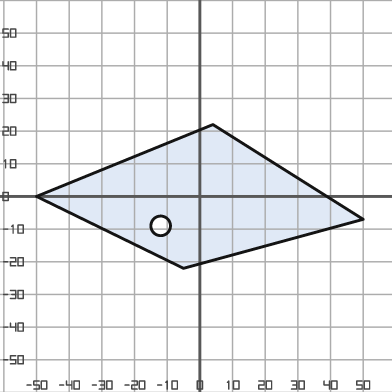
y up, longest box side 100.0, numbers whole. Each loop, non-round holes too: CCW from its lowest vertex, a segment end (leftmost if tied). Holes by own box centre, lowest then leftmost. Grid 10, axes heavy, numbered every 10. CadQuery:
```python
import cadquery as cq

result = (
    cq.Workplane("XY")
    .moveTo(-5.0, -22.0)
    .lineTo(50.0, -7.0)
    .lineTo(4.0, 22.0)
    .lineTo(-50.0, 0.0)
    .close()
    .moveTo(-12.0, -9.0)
    .circle(3.0)
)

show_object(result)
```